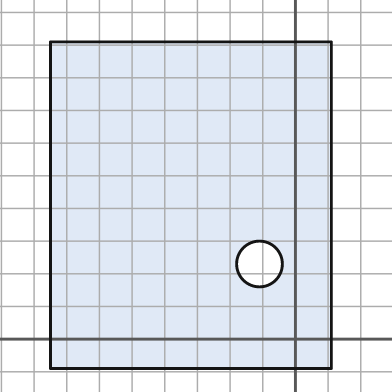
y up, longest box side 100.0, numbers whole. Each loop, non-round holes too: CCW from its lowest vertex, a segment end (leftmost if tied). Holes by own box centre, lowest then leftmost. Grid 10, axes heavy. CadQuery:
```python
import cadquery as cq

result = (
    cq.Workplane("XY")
    .moveTo(-75.0, -9.0)
    .lineTo(11.0, -9.0)
    .lineTo(11.0, 91.0)
    .lineTo(-75.0, 91.0)
    .close()
    .moveTo(-11.0, 23.0)
    .circle(7.0)
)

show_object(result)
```